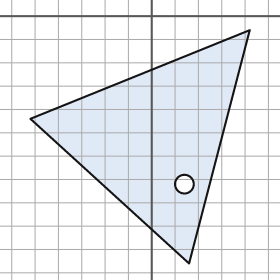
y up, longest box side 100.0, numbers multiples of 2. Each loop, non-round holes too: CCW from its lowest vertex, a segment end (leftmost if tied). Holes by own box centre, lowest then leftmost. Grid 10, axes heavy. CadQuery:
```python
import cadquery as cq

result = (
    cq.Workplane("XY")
    .moveTo(16.0, -106.0)
    .lineTo(42.0, -6.0)
    .lineTo(-52.0, -44.0)
    .close()
    .moveTo(14.0, -72.0)
    .circle(4.0)
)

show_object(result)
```